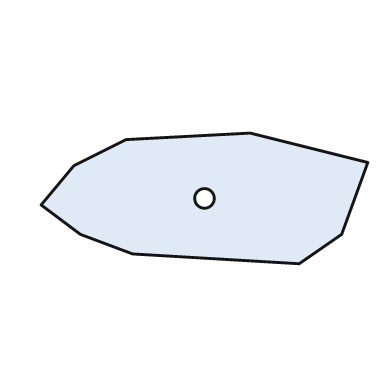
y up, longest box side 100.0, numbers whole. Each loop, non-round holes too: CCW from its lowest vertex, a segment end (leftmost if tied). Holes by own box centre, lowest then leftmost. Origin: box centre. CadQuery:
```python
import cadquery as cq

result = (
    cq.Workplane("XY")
    .moveTo(29.0, -20.0)
    .lineTo(42.0, -11.0)
    .lineTo(50.0, 11.0)
    .lineTo(14.0, 20.0)
    .lineTo(-24.0, 18.0)
    .lineTo(-40.0, 10.0)
    .lineTo(-50.0, -2.0)
    .lineTo(-38.0, -11.0)
    .lineTo(-22.0, -17.0)
    .close()
    .moveTo(0.0, 0.0)
    .circle(3.0)
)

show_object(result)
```